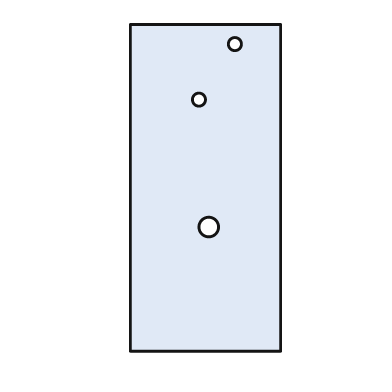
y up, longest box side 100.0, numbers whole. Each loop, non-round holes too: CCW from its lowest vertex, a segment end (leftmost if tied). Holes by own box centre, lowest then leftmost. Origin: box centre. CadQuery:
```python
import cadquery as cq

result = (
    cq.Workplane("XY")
    .moveTo(-23.0, -50.0)
    .lineTo(23.0, -50.0)
    .lineTo(23.0, 50.0)
    .lineTo(-23.0, 50.0)
    .close()
    .moveTo(1.0, -12.0)
    .circle(3.0)
    .moveTo(-2.0, 27.0)
    .circle(2.0)
    .moveTo(9.0, 44.0)
    .circle(2.0)
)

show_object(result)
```